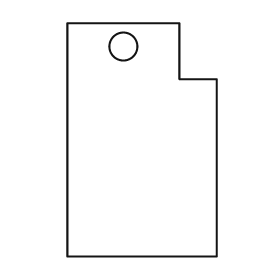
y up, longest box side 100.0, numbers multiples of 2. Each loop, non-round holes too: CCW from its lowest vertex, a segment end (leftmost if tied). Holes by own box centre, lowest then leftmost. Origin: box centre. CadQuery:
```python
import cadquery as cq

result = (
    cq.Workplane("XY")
    .moveTo(-32.0, -50.0)
    .lineTo(32.0, -50.0)
    .lineTo(32.0, 26.0)
    .lineTo(16.0, 26.0)
    .lineTo(16.0, 50.0)
    .lineTo(-32.0, 50.0)
    .close()
    .moveTo(-8.0, 40.0)
    .circle(6.0)
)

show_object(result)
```